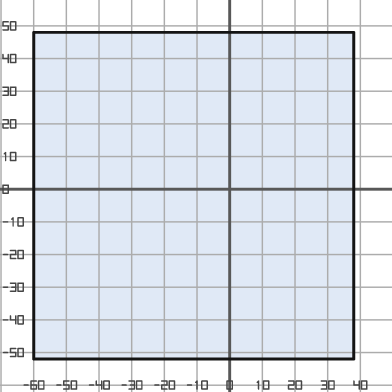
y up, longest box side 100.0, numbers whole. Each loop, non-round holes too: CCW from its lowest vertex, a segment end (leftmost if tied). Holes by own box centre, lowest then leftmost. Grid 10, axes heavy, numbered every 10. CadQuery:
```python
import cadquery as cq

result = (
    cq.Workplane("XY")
    .moveTo(-60.0, -52.0)
    .lineTo(38.0, -52.0)
    .lineTo(38.0, 48.0)
    .lineTo(-60.0, 48.0)
    .close()
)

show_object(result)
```